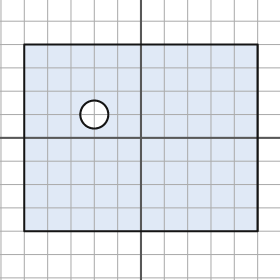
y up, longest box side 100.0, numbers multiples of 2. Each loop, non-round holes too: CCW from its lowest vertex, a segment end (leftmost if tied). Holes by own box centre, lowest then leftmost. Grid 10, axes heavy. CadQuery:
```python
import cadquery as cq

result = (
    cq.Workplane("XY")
    .moveTo(-50.0, -40.0)
    .lineTo(50.0, -40.0)
    .lineTo(50.0, 40.0)
    .lineTo(-50.0, 40.0)
    .close()
    .moveTo(-20.0, 10.0)
    .circle(6.0)
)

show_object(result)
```